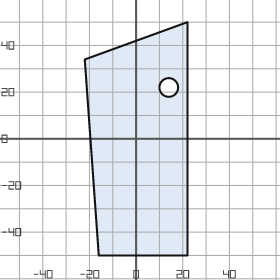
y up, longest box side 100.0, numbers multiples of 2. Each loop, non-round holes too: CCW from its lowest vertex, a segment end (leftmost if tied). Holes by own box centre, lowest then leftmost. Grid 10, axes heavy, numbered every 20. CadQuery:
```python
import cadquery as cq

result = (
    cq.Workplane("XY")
    .moveTo(-16.0, -50.0)
    .lineTo(22.0, -50.0)
    .lineTo(22.0, 50.0)
    .lineTo(-22.0, 34.0)
    .close()
    .moveTo(14.0, 22.0)
    .circle(4.0)
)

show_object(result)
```